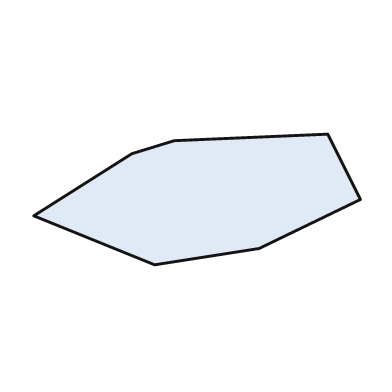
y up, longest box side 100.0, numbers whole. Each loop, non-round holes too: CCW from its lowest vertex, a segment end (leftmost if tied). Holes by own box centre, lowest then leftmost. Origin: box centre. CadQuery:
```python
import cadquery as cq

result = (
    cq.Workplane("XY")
    .moveTo(-13.0, -20.0)
    .lineTo(19.0, -15.0)
    .lineTo(50.0, 0.0)
    .lineTo(40.0, 20.0)
    .lineTo(-7.0, 18.0)
    .lineTo(-20.0, 14.0)
    .lineTo(-50.0, -5.0)
    .close()
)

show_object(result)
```